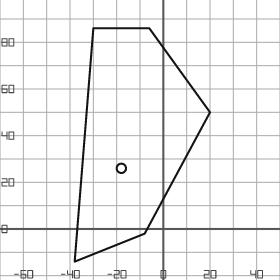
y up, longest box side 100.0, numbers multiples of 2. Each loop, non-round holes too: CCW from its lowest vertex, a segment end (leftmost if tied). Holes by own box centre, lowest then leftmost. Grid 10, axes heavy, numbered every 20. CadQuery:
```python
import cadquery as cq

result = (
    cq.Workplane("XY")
    .moveTo(-38.0, -14.0)
    .lineTo(-8.0, -2.0)
    .lineTo(20.0, 50.0)
    .lineTo(-6.0, 86.0)
    .lineTo(-30.0, 86.0)
    .close()
    .moveTo(-18.0, 26.0)
    .circle(2.0)
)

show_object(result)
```